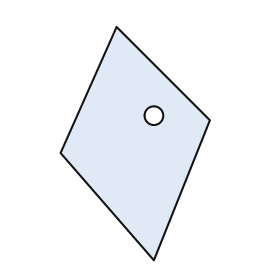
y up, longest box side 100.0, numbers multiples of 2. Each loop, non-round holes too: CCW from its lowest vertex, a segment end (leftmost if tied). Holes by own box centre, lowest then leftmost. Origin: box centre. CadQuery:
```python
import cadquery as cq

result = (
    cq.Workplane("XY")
    .moveTo(8.0, -50.0)
    .lineTo(32.0, 10.0)
    .lineTo(-8.0, 50.0)
    .lineTo(-32.0, -4.0)
    .close()
    .moveTo(8.0, 12.0)
    .circle(4.0)
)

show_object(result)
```